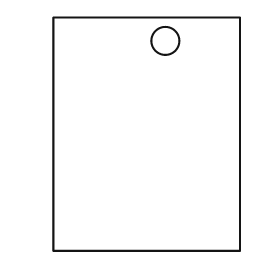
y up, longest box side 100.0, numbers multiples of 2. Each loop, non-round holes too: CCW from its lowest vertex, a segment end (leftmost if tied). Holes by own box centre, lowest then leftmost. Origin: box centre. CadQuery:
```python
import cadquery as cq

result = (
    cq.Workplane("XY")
    .moveTo(-40.0, -50.0)
    .lineTo(40.0, -50.0)
    .lineTo(40.0, 50.0)
    .lineTo(-40.0, 50.0)
    .close()
    .moveTo(8.0, 40.0)
    .circle(6.0)
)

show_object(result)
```